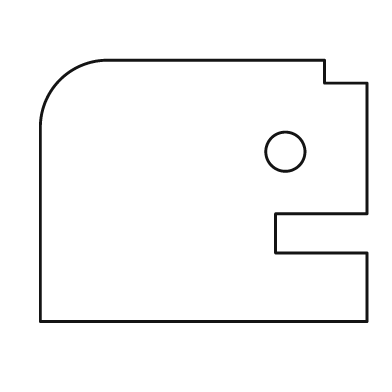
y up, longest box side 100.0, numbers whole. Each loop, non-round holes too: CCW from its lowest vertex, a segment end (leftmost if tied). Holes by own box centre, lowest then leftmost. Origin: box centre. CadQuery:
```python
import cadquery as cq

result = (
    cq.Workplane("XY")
    .moveTo(-50.0, -40.0)
    .lineTo(50.0, -40.0)
    .lineTo(50.0, -19.0)
    .lineTo(22.0, -19.0)
    .lineTo(22.0, -7.0)
    .lineTo(50.0, -7.0)
    .lineTo(50.0, 33.0)
    .lineTo(37.0, 33.0)
    .lineTo(37.0, 40.0)
    .lineTo(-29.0, 40.0)
    .threePointArc((-44.0, 34.0), (-50.0, 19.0))
    .close()
    .moveTo(25.0, 12.0)
    .circle(6.0)
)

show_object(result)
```